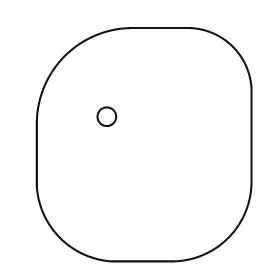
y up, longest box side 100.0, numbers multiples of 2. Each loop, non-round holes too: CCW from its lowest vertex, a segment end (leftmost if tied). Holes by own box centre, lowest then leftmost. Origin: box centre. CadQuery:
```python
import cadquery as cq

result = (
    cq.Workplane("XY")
    .moveTo(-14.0, -50.0)
    .lineTo(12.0, -50.0)
    .threePointArc((36.0, -40.0), (46.0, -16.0))
    .lineTo(46.0, 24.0)
    .threePointArc((38.0, 42.0), (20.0, 50.0))
    .lineTo(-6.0, 50.0)
    .threePointArc((-34.0, 38.0), (-46.0, 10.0))
    .lineTo(-46.0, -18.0)
    .threePointArc((-36.0, -40.0), (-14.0, -50.0))
    .close()
    .moveTo(-16.0, 12.0)
    .circle(4.0)
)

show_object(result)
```